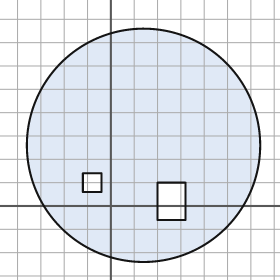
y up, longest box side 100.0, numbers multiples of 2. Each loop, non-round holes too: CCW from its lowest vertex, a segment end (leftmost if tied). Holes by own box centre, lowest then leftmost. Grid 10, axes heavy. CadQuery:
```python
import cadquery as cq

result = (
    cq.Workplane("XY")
    .moveTo(14.0, 26.0)
    .circle(50.0)
    .moveTo(20.0, -6.0)
    .lineTo(32.0, -6.0)
    .lineTo(32.0, 10.0)
    .lineTo(20.0, 10.0)
    .close()
    .moveTo(-12.0, 6.0)
    .lineTo(-4.0, 6.0)
    .lineTo(-4.0, 14.0)
    .lineTo(-12.0, 14.0)
    .close()
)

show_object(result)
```